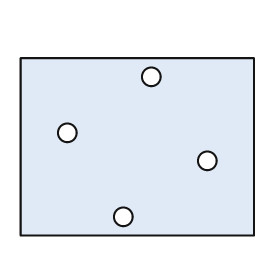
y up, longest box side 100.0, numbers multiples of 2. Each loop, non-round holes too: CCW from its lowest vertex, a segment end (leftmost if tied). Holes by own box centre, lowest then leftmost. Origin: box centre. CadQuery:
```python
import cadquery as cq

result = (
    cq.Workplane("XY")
    .moveTo(-50.0, -38.0)
    .lineTo(50.0, -38.0)
    .lineTo(50.0, 38.0)
    .lineTo(-50.0, 38.0)
    .close()
    .moveTo(-6.0, -30.0)
    .circle(4.0)
    .moveTo(30.0, -6.0)
    .circle(4.0)
    .moveTo(-30.0, 6.0)
    .circle(4.0)
    .moveTo(6.0, 30.0)
    .circle(4.0)
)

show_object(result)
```